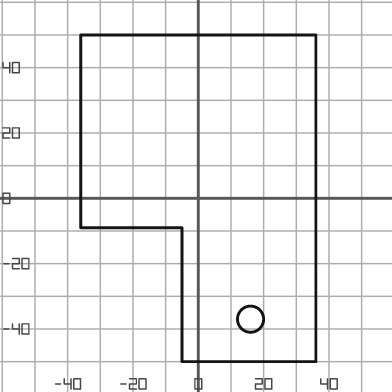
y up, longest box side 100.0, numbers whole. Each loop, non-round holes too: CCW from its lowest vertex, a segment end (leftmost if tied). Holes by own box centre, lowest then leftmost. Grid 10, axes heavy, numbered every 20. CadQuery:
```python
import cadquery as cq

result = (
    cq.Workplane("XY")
    .moveTo(-5.0, -50.0)
    .lineTo(36.0, -50.0)
    .lineTo(36.0, 50.0)
    .lineTo(-36.0, 50.0)
    .lineTo(-36.0, -9.0)
    .lineTo(-5.0, -9.0)
    .close()
    .moveTo(16.0, -37.0)
    .circle(4.0)
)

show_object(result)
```